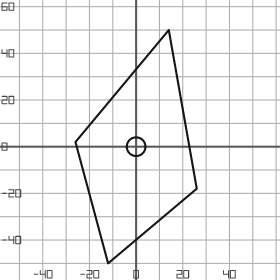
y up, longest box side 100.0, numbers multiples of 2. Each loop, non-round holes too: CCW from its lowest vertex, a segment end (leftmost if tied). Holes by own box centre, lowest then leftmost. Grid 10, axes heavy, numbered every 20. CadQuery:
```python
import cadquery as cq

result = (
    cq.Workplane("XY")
    .moveTo(-12.0, -50.0)
    .lineTo(26.0, -18.0)
    .lineTo(14.0, 50.0)
    .lineTo(-26.0, 2.0)
    .close()
    .moveTo(0.0, 0.0)
    .circle(4.0)
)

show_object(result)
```